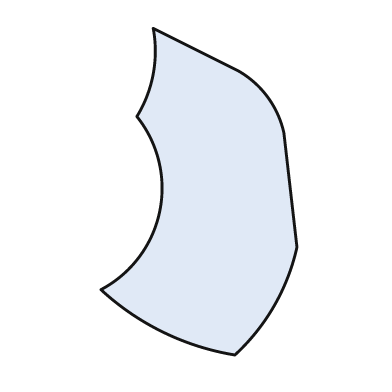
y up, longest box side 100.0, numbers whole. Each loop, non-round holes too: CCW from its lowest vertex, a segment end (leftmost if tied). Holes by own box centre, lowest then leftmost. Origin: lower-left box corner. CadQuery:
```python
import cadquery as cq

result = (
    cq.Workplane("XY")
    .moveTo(41.0, 0.0)
    .threePointArc((53.0, 15.0), (60.0, 33.0))
    .lineTo(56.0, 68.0)
    .threePointArc((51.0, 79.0), (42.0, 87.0))
    .lineTo(16.0, 100.0)
    .threePointArc((16.0, 86.0), (11.0, 73.0))
    .threePointArc((18.0, 44.0), (0.0, 20.0))
    .threePointArc((19.0, 7.0), (41.0, 0.0))
    .close()
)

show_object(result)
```